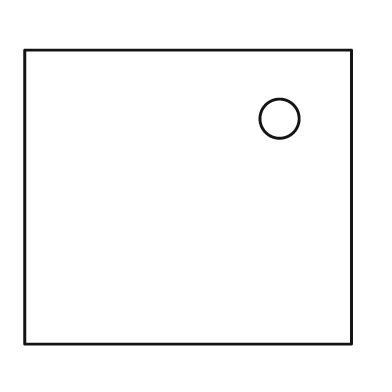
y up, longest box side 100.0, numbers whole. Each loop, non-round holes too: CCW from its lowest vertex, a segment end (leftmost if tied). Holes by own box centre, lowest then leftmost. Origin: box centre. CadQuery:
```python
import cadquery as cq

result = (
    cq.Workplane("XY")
    .moveTo(-50.0, -45.0)
    .lineTo(50.0, -45.0)
    .lineTo(50.0, 45.0)
    .lineTo(-50.0, 45.0)
    .close()
    .moveTo(28.0, 24.0)
    .circle(6.0)
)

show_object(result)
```